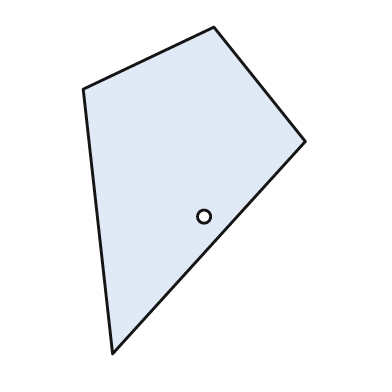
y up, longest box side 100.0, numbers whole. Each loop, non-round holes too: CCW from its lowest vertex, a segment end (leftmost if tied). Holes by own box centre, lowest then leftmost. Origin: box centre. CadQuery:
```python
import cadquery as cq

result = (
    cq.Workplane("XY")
    .moveTo(-25.0, -50.0)
    .lineTo(34.0, 15.0)
    .lineTo(6.0, 50.0)
    .lineTo(-34.0, 31.0)
    .close()
    .moveTo(3.0, -8.0)
    .circle(2.0)
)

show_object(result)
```